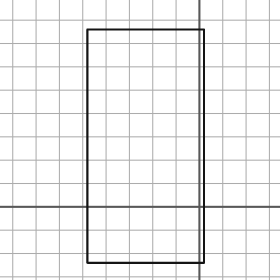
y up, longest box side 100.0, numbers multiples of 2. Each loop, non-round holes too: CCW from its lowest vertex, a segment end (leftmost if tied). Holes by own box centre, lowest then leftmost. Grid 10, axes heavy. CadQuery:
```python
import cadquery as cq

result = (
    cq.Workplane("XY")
    .moveTo(-48.0, -24.0)
    .lineTo(2.0, -24.0)
    .lineTo(2.0, 76.0)
    .lineTo(-48.0, 76.0)
    .close()
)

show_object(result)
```